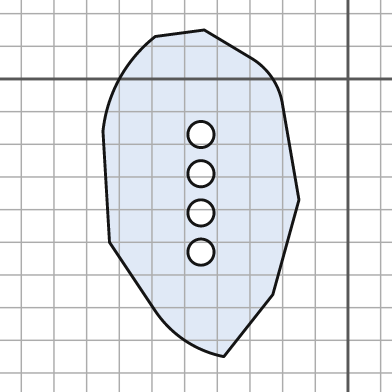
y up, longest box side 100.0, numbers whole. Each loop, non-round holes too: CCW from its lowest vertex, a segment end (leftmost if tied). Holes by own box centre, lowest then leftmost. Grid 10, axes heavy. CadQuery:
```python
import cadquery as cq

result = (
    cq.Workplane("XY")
    .moveTo(-38.0, -85.0)
    .lineTo(-23.0, -66.0)
    .lineTo(-15.0, -37.0)
    .lineTo(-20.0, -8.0)
    .threePointArc((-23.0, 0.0), (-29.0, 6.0))
    .lineTo(-44.0, 15.0)
    .lineTo(-59.0, 13.0)
    .threePointArc((-70.0, 0.0), (-75.0, -16.0))
    .lineTo(-73.0, -50.0)
    .lineTo(-59.0, -71.0)
    .threePointArc((-50.0, -80.0), (-38.0, -85.0))
    .close()
    .moveTo(-45.0, -53.0)
    .circle(4.0)
    .moveTo(-45.0, -41.0)
    .circle(4.0)
    .moveTo(-45.0, -29.0)
    .circle(4.0)
    .moveTo(-45.0, -17.0)
    .circle(4.0)
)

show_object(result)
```